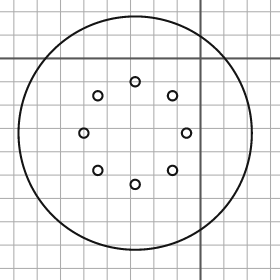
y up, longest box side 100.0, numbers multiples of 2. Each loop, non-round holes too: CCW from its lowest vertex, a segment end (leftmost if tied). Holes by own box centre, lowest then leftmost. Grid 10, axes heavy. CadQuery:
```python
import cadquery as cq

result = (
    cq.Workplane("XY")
    .moveTo(-28.0, -32.0)
    .circle(50.0)
    .moveTo(-28.0, -54.0)
    .circle(2.0)
    .moveTo(-44.0, -48.0)
    .circle(2.0)
    .moveTo(-12.0, -48.0)
    .circle(2.0)
    .moveTo(-50.0, -32.0)
    .circle(2.0)
    .moveTo(-6.0, -32.0)
    .circle(2.0)
    .moveTo(-44.0, -16.0)
    .circle(2.0)
    .moveTo(-12.0, -16.0)
    .circle(2.0)
    .moveTo(-28.0, -10.0)
    .circle(2.0)
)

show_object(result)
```